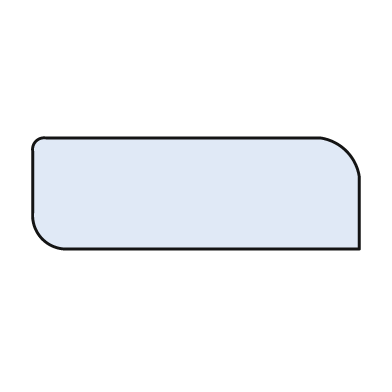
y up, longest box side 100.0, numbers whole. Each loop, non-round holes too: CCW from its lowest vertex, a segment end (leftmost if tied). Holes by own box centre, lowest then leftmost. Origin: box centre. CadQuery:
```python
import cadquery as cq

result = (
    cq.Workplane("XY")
    .moveTo(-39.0, -17.0)
    .lineTo(50.0, -17.0)
    .lineTo(50.0, 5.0)
    .threePointArc((46.0, 13.0), (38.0, 17.0))
    .lineTo(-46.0, 17.0)
    .threePointArc((-49.0, 16.0), (-50.0, 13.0))
    .lineTo(-50.0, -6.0)
    .threePointArc((-47.0, -14.0), (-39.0, -17.0))
    .close()
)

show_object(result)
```